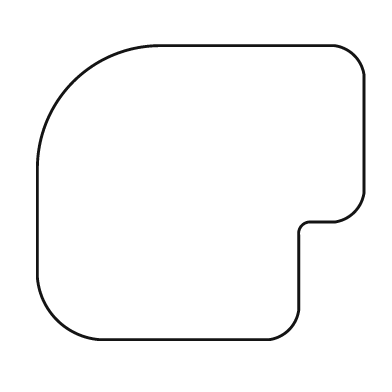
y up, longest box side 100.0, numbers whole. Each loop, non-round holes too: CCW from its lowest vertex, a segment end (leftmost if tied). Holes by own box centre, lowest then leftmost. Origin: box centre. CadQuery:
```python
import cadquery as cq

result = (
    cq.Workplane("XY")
    .moveTo(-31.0, -45.0)
    .lineTo(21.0, -45.0)
    .threePointArc((27.0, -42.0), (30.0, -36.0))
    .lineTo(30.0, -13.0)
    .threePointArc((31.0, -10.0), (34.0, -9.0))
    .lineTo(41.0, -9.0)
    .threePointArc((47.0, -6.0), (50.0, 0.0))
    .lineTo(50.0, 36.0)
    .threePointArc((47.0, 42.0), (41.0, 45.0))
    .lineTo(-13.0, 45.0)
    .threePointArc((-39.0, 34.0), (-50.0, 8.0))
    .lineTo(-50.0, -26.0)
    .threePointArc((-44.0, -39.0), (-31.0, -45.0))
    .close()
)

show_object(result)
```